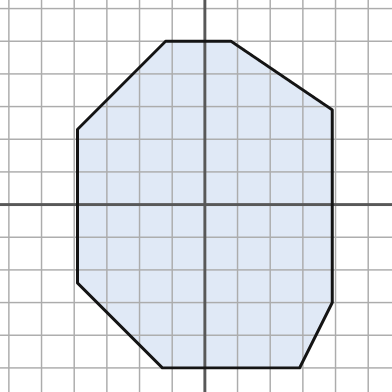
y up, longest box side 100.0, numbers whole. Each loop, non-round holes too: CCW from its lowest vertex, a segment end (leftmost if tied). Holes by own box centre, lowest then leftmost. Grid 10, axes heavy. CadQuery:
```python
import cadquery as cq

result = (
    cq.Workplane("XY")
    .moveTo(-13.0, -50.0)
    .lineTo(29.0, -50.0)
    .lineTo(39.0, -30.0)
    .lineTo(39.0, 29.0)
    .lineTo(8.0, 50.0)
    .lineTo(-12.0, 50.0)
    .lineTo(-39.0, 23.0)
    .lineTo(-39.0, -24.0)
    .close()
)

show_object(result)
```